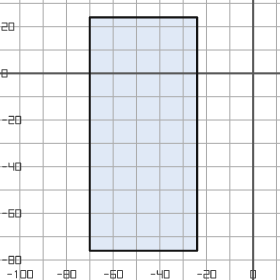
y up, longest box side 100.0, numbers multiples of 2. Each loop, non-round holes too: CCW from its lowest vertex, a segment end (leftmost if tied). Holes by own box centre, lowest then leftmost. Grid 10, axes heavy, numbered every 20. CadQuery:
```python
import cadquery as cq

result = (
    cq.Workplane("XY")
    .moveTo(-70.0, -76.0)
    .lineTo(-24.0, -76.0)
    .lineTo(-24.0, 24.0)
    .lineTo(-70.0, 24.0)
    .close()
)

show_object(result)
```